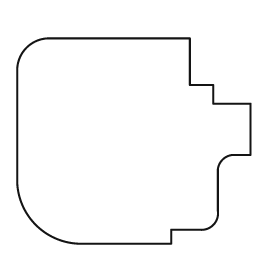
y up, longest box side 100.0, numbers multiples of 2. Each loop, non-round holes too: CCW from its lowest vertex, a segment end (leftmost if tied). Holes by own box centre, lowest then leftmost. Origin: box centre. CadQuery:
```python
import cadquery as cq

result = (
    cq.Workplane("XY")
    .moveTo(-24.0, -44.0)
    .lineTo(16.0, -44.0)
    .lineTo(16.0, -38.0)
    .lineTo(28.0, -38.0)
    .threePointArc((34.0, -36.0), (36.0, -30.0))
    .lineTo(36.0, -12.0)
    .threePointArc((38.0, -8.0), (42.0, -6.0))
    .lineTo(50.0, -6.0)
    .lineTo(50.0, 16.0)
    .lineTo(34.0, 16.0)
    .lineTo(34.0, 24.0)
    .lineTo(24.0, 24.0)
    .lineTo(24.0, 44.0)
    .lineTo(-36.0, 44.0)
    .threePointArc((-46.0, 40.0), (-50.0, 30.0))
    .lineTo(-50.0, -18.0)
    .threePointArc((-42.0, -36.0), (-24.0, -44.0))
    .close()
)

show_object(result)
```